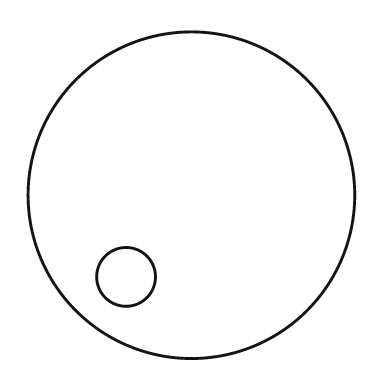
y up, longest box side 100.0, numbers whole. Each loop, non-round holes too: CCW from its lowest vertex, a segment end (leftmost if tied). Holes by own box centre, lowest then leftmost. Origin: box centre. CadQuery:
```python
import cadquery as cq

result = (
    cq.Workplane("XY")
    .moveTo(0.0, 0.0)
    .circle(50.0)
    .moveTo(-20.0, -25.0)
    .circle(9.0)
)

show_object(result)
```